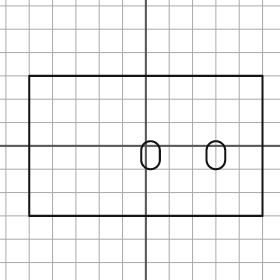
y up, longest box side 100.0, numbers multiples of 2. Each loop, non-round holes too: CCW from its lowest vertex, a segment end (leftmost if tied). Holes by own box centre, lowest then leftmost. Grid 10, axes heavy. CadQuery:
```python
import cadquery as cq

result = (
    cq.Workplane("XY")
    .moveTo(-50.0, -30.0)
    .lineTo(50.0, -30.0)
    .lineTo(50.0, 30.0)
    .lineTo(-50.0, 30.0)
    .close()
    .moveTo(-2.0, -6.0)
    .threePointArc((2.0, -10.0), (6.0, -6.0))
    .lineTo(6.0, -2.0)
    .threePointArc((2.0, 2.0), (-2.0, -2.0))
    .close()
    .moveTo(26.0, -6.0)
    .threePointArc((30.0, -10.0), (34.0, -6.0))
    .lineTo(34.0, -2.0)
    .threePointArc((30.0, 2.0), (26.0, -2.0))
    .close()
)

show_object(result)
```